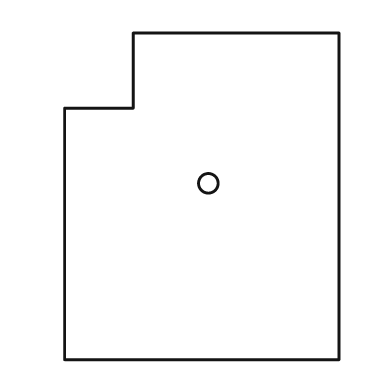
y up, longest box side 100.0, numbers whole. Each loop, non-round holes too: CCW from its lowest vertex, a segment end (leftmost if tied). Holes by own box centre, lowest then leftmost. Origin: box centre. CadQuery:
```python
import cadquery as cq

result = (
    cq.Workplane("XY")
    .moveTo(-42.0, -50.0)
    .lineTo(42.0, -50.0)
    .lineTo(42.0, 50.0)
    .lineTo(-21.0, 50.0)
    .lineTo(-21.0, 27.0)
    .lineTo(-42.0, 27.0)
    .close()
    .moveTo(2.0, 4.0)
    .circle(3.0)
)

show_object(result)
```